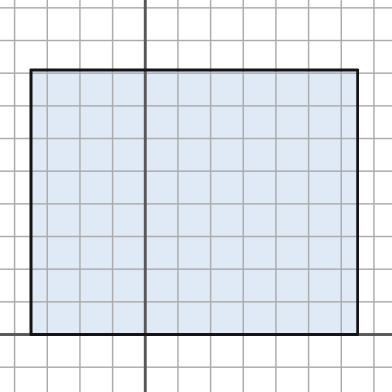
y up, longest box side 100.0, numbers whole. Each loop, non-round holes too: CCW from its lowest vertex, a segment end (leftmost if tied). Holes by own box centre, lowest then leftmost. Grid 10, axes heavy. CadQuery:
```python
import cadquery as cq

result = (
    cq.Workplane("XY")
    .moveTo(-35.0, 0.0)
    .lineTo(65.0, 0.0)
    .lineTo(65.0, 81.0)
    .lineTo(-35.0, 81.0)
    .close()
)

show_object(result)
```